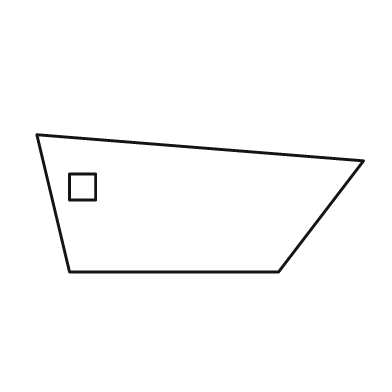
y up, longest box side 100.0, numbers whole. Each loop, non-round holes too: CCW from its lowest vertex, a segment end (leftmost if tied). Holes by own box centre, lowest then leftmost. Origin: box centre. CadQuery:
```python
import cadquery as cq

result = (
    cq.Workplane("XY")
    .moveTo(-40.0, -21.0)
    .lineTo(24.0, -21.0)
    .lineTo(50.0, 13.0)
    .lineTo(-50.0, 21.0)
    .close()
    .moveTo(-40.0, 1.0)
    .lineTo(-32.0, 1.0)
    .lineTo(-32.0, 9.0)
    .lineTo(-40.0, 9.0)
    .close()
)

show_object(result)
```